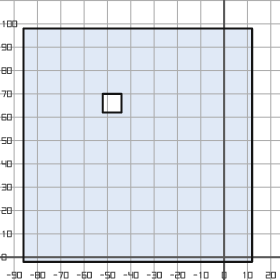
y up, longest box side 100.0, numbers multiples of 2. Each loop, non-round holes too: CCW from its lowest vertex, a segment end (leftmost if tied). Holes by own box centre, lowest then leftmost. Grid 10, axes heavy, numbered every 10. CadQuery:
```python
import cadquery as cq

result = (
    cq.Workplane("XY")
    .moveTo(-86.0, -2.0)
    .lineTo(12.0, -2.0)
    .lineTo(12.0, 98.0)
    .lineTo(-86.0, 98.0)
    .close()
    .moveTo(-52.0, 62.0)
    .lineTo(-44.0, 62.0)
    .lineTo(-44.0, 70.0)
    .lineTo(-52.0, 70.0)
    .close()
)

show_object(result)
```